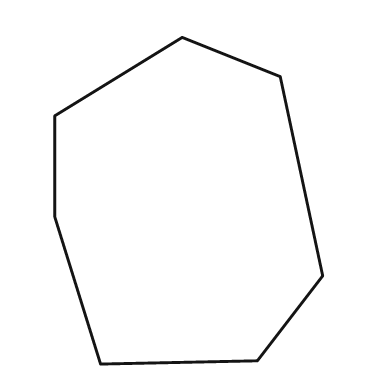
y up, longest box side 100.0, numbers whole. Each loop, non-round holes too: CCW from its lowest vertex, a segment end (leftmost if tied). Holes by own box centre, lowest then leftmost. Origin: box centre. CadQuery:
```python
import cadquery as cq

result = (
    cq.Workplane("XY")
    .moveTo(-27.0, -50.0)
    .lineTo(21.0, -49.0)
    .lineTo(41.0, -23.0)
    .lineTo(28.0, 38.0)
    .lineTo(-2.0, 50.0)
    .lineTo(-41.0, 26.0)
    .lineTo(-41.0, -5.0)
    .close()
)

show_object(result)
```